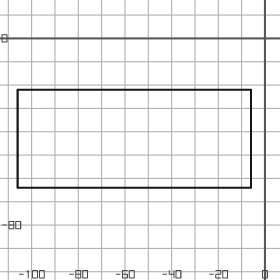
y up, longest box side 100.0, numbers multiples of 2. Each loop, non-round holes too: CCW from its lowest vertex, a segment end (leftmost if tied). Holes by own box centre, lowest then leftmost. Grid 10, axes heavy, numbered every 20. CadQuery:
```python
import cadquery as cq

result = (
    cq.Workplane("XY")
    .moveTo(-106.0, -64.0)
    .lineTo(-6.0, -64.0)
    .lineTo(-6.0, -22.0)
    .lineTo(-106.0, -22.0)
    .close()
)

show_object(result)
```